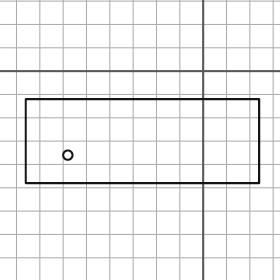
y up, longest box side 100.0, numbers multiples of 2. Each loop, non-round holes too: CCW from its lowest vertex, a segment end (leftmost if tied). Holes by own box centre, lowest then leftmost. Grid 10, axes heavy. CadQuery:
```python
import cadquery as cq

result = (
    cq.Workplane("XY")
    .moveTo(-76.0, -48.0)
    .lineTo(24.0, -48.0)
    .lineTo(24.0, -12.0)
    .lineTo(-76.0, -12.0)
    .close()
    .moveTo(-58.0, -36.0)
    .circle(2.0)
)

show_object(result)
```